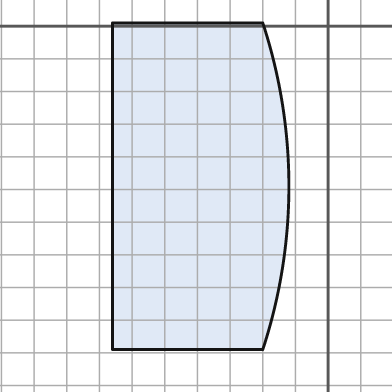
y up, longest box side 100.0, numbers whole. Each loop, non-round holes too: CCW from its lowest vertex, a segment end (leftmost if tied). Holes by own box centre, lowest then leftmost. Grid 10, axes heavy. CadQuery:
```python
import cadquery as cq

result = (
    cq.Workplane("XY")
    .moveTo(-66.0, -99.0)
    .lineTo(-20.0, -99.0)
    .threePointArc((-12.0, -49.0), (-20.0, 1.0))
    .lineTo(-66.0, 1.0)
    .close()
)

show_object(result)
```